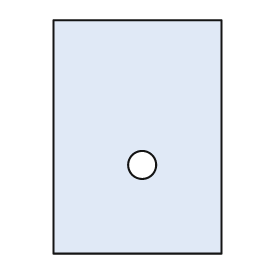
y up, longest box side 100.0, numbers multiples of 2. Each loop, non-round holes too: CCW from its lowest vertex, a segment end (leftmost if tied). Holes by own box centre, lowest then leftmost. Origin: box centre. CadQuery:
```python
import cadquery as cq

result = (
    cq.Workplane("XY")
    .moveTo(-36.0, -50.0)
    .lineTo(36.0, -50.0)
    .lineTo(36.0, 50.0)
    .lineTo(-36.0, 50.0)
    .close()
    .moveTo(2.0, -12.0)
    .circle(6.0)
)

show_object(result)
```